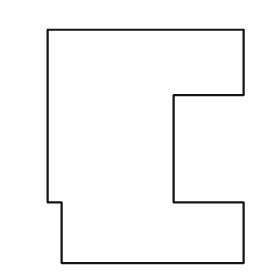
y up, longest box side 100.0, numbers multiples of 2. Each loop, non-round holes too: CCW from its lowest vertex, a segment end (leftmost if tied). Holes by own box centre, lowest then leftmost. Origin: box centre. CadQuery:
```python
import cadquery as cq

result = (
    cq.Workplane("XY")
    .moveTo(-36.0, -50.0)
    .lineTo(42.0, -50.0)
    .lineTo(42.0, -24.0)
    .lineTo(12.0, -24.0)
    .lineTo(12.0, 22.0)
    .lineTo(42.0, 22.0)
    .lineTo(42.0, 50.0)
    .lineTo(-42.0, 50.0)
    .lineTo(-42.0, -24.0)
    .lineTo(-36.0, -24.0)
    .close()
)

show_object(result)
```